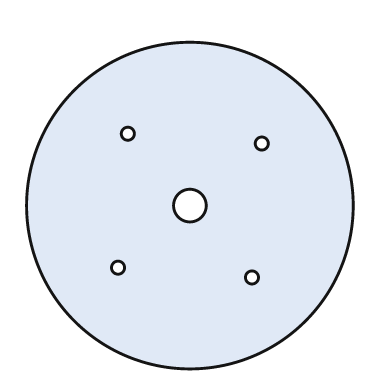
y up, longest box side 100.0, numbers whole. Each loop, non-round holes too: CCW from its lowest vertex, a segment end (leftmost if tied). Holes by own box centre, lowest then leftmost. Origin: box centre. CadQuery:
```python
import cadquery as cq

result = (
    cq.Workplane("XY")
    .moveTo(0.0, 0.0)
    .circle(50.0)
    .moveTo(19.0, -22.0)
    .circle(2.0)
    .moveTo(-22.0, -19.0)
    .circle(2.0)
    .moveTo(0.0, 0.0)
    .circle(5.0)
    .moveTo(22.0, 19.0)
    .circle(2.0)
    .moveTo(-19.0, 22.0)
    .circle(2.0)
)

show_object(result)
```